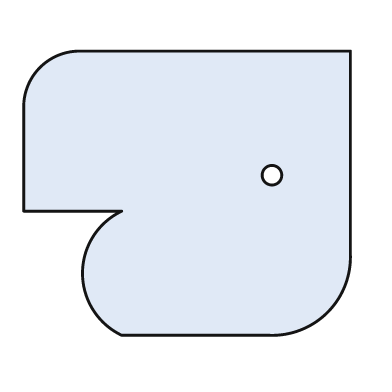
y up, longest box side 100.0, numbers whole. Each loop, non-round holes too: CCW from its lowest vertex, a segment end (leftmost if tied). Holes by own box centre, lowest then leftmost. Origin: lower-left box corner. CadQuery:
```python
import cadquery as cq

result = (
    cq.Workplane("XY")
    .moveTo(30.0, 0.0)
    .lineTo(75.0, 0.0)
    .threePointArc((93.0, 7.0), (100.0, 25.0))
    .lineTo(100.0, 87.0)
    .lineTo(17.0, 87.0)
    .threePointArc((5.0, 82.0), (0.0, 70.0))
    .lineTo(0.0, 38.0)
    .lineTo(30.0, 38.0)
    .threePointArc((18.0, 19.0), (30.0, 0.0))
    .close()
    .moveTo(76.0, 49.0)
    .circle(3.0)
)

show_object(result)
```